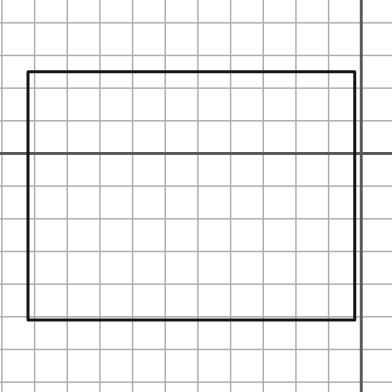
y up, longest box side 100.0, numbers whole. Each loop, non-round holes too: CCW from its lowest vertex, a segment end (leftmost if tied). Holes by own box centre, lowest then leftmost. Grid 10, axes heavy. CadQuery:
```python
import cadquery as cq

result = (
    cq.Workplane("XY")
    .moveTo(-102.0, -51.0)
    .lineTo(-2.0, -51.0)
    .lineTo(-2.0, 25.0)
    .lineTo(-102.0, 25.0)
    .close()
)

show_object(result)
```